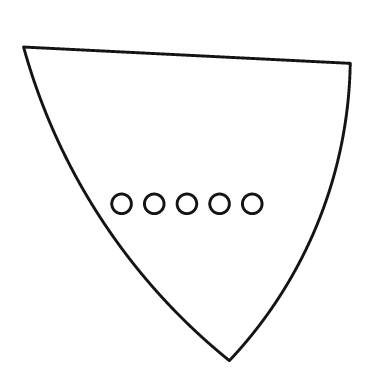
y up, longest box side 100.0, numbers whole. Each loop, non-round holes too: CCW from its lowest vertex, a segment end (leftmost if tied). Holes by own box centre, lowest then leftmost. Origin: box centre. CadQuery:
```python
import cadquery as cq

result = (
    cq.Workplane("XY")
    .moveTo(13.0, -48.0)
    .threePointArc((40.0, -6.0), (50.0, 43.0))
    .lineTo(-50.0, 48.0)
    .threePointArc((-26.0, -5.0), (13.0, -48.0))
    .close()
    .moveTo(-20.0, 0.0)
    .circle(3.0)
    .moveTo(-10.0, 0.0)
    .circle(3.0)
    .moveTo(0.0, 0.0)
    .circle(3.0)
    .moveTo(10.0, 0.0)
    .circle(3.0)
    .moveTo(20.0, 0.0)
    .circle(3.0)
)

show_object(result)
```